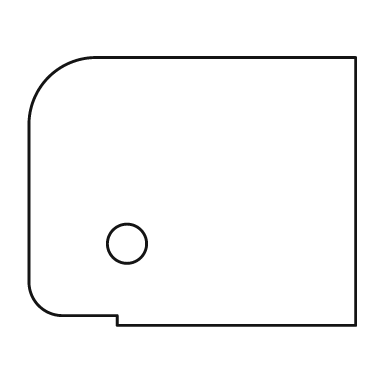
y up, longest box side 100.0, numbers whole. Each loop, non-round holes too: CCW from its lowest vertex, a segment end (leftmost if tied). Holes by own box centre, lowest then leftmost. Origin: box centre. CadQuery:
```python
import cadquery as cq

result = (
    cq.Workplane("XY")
    .moveTo(-23.0, -41.0)
    .lineTo(50.0, -41.0)
    .lineTo(50.0, 41.0)
    .lineTo(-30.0, 41.0)
    .threePointArc((-44.0, 35.0), (-50.0, 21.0))
    .lineTo(-50.0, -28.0)
    .threePointArc((-47.0, -35.0), (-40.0, -38.0))
    .lineTo(-23.0, -38.0)
    .close()
    .moveTo(-20.0, -16.0)
    .circle(6.0)
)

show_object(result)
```